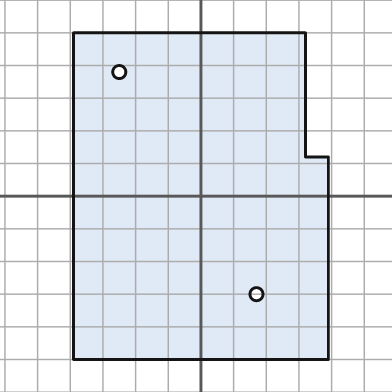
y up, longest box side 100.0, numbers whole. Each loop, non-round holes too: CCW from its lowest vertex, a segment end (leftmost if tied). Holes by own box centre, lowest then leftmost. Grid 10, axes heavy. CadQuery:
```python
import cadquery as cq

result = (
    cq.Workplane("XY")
    .moveTo(-39.0, -50.0)
    .lineTo(39.0, -50.0)
    .lineTo(39.0, 12.0)
    .lineTo(32.0, 12.0)
    .lineTo(32.0, 50.0)
    .lineTo(-39.0, 50.0)
    .close()
    .moveTo(17.0, -30.0)
    .circle(2.0)
    .moveTo(-25.0, 38.0)
    .circle(2.0)
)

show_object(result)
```